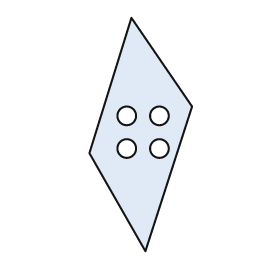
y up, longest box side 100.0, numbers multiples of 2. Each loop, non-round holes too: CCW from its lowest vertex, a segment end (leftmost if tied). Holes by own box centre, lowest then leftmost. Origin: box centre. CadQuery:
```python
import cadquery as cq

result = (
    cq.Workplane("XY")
    .moveTo(2.0, -50.0)
    .lineTo(22.0, 12.0)
    .lineTo(-4.0, 50.0)
    .lineTo(-22.0, -8.0)
    .close()
    .moveTo(-6.0, -6.0)
    .circle(4.0)
    .moveTo(8.0, -6.0)
    .circle(4.0)
    .moveTo(-6.0, 8.0)
    .circle(4.0)
    .moveTo(8.0, 8.0)
    .circle(4.0)
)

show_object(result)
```